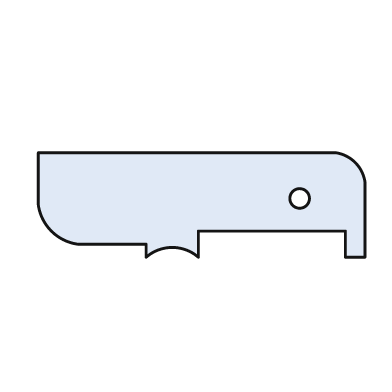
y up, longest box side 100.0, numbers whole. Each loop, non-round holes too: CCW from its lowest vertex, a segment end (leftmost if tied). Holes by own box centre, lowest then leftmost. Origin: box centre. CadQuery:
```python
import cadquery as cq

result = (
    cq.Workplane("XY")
    .moveTo(-17.0, -16.0)
    .threePointArc((-9.0, -13.0), (-1.0, -16.0))
    .lineTo(-1.0, -8.0)
    .lineTo(44.0, -8.0)
    .lineTo(44.0, -16.0)
    .lineTo(50.0, -16.0)
    .lineTo(50.0, 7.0)
    .threePointArc((47.0, 13.0), (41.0, 16.0))
    .lineTo(-50.0, 16.0)
    .lineTo(-50.0, 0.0)
    .threePointArc((-46.0, -8.0), (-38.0, -12.0))
    .lineTo(-17.0, -12.0)
    .close()
    .moveTo(30.0, 2.0)
    .circle(3.0)
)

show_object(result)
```